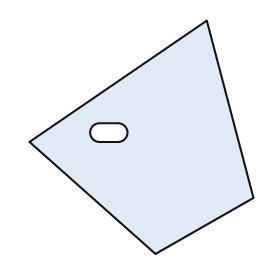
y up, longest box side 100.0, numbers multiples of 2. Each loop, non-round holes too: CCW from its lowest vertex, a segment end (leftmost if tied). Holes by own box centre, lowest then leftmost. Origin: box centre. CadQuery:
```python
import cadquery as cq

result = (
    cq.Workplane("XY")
    .moveTo(6.0, -50.0)
    .lineTo(48.0, -26.0)
    .lineTo(28.0, 50.0)
    .lineTo(-48.0, -2.0)
    .close()
    .moveTo(-18.0, -2.0)
    .lineTo(-10.0, -2.0)
    .threePointArc((-6.0, 2.0), (-10.0, 6.0))
    .lineTo(-18.0, 6.0)
    .threePointArc((-22.0, 2.0), (-18.0, -2.0))
    .close()
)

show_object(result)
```